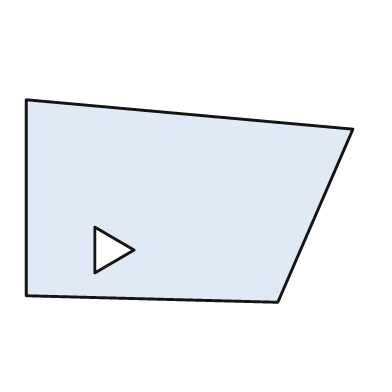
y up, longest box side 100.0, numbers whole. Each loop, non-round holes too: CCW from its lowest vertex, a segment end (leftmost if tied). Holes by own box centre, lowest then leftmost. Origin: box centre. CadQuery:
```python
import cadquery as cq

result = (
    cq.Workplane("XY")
    .moveTo(27.0, -31.0)
    .lineTo(50.0, 22.0)
    .lineTo(-50.0, 31.0)
    .lineTo(-50.0, -29.0)
    .close()
    .moveTo(-29.0, -22.0)
    .lineTo(-17.0, -15.0)
    .lineTo(-29.0, -8.0)
    .close()
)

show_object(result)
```